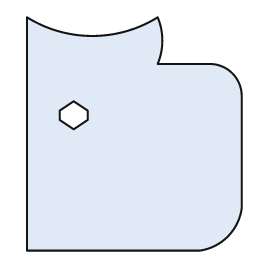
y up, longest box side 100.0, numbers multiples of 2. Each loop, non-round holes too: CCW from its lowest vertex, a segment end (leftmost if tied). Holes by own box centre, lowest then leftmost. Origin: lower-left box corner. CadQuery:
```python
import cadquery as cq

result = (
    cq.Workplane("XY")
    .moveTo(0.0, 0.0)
    .lineTo(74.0, 0.0)
    .threePointArc((86.0, 6.0), (92.0, 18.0))
    .lineTo(92.0, 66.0)
    .threePointArc((88.0, 76.0), (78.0, 80.0))
    .lineTo(56.0, 80.0)
    .threePointArc((58.0, 90.0), (56.0, 100.0))
    .threePointArc((28.0, 92.0), (0.0, 100.0))
    .close()
    .moveTo(20.0, 52.0)
    .lineTo(26.0, 56.0)
    .lineTo(26.0, 60.0)
    .lineTo(20.0, 64.0)
    .lineTo(14.0, 60.0)
    .lineTo(14.0, 56.0)
    .close()
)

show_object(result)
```